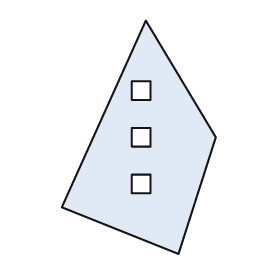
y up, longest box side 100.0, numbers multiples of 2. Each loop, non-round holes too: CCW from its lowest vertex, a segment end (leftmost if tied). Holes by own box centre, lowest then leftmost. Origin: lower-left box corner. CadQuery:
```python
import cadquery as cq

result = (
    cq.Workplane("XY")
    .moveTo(50.0, 0.0)
    .lineTo(66.0, 50.0)
    .lineTo(36.0, 100.0)
    .lineTo(0.0, 20.0)
    .close()
    .moveTo(30.0, 26.0)
    .lineTo(38.0, 26.0)
    .lineTo(38.0, 34.0)
    .lineTo(30.0, 34.0)
    .close()
    .moveTo(30.0, 46.0)
    .lineTo(38.0, 46.0)
    .lineTo(38.0, 54.0)
    .lineTo(30.0, 54.0)
    .close()
    .moveTo(30.0, 66.0)
    .lineTo(38.0, 66.0)
    .lineTo(38.0, 74.0)
    .lineTo(30.0, 74.0)
    .close()
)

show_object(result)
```